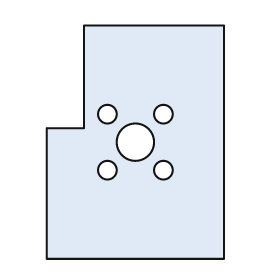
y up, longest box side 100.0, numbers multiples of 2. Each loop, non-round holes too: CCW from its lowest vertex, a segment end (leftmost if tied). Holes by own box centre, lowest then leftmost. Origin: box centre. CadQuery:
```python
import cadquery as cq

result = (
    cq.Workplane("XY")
    .moveTo(-38.0, -50.0)
    .lineTo(38.0, -50.0)
    .lineTo(38.0, 50.0)
    .lineTo(-22.0, 50.0)
    .lineTo(-22.0, 6.0)
    .lineTo(-38.0, 6.0)
    .close()
    .moveTo(-12.0, -12.0)
    .circle(4.0)
    .moveTo(12.0, -12.0)
    .circle(4.0)
    .moveTo(0.0, 0.0)
    .circle(8.0)
    .moveTo(-12.0, 12.0)
    .circle(4.0)
    .moveTo(12.0, 12.0)
    .circle(4.0)
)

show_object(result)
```